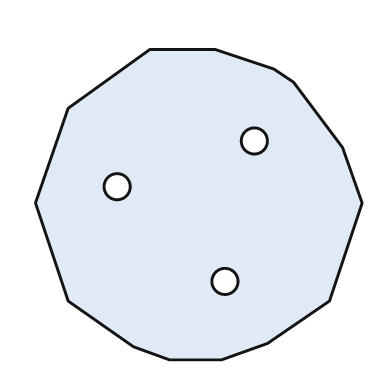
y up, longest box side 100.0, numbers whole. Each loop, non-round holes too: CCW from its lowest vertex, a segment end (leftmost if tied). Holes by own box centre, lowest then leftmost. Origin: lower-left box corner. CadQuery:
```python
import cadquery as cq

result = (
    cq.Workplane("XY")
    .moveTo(41.0, 0.0)
    .lineTo(57.0, 0.0)
    .lineTo(71.0, 5.0)
    .lineTo(90.0, 18.0)
    .lineTo(100.0, 48.0)
    .lineTo(94.0, 65.0)
    .lineTo(79.0, 85.0)
    .lineTo(73.0, 89.0)
    .lineTo(55.0, 95.0)
    .lineTo(35.0, 95.0)
    .lineTo(10.0, 77.0)
    .lineTo(0.0, 48.0)
    .lineTo(10.0, 18.0)
    .lineTo(30.0, 4.0)
    .close()
    .moveTo(58.0, 24.0)
    .circle(4.0)
    .moveTo(25.0, 53.0)
    .circle(4.0)
    .moveTo(67.0, 67.0)
    .circle(4.0)
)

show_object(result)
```